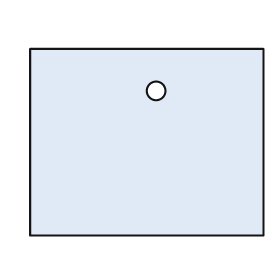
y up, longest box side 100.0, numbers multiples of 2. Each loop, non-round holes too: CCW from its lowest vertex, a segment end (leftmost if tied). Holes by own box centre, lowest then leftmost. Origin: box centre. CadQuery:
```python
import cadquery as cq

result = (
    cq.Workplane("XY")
    .moveTo(-50.0, -40.0)
    .lineTo(50.0, -40.0)
    .lineTo(50.0, 40.0)
    .lineTo(-50.0, 40.0)
    .close()
    .moveTo(4.0, 22.0)
    .circle(4.0)
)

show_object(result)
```